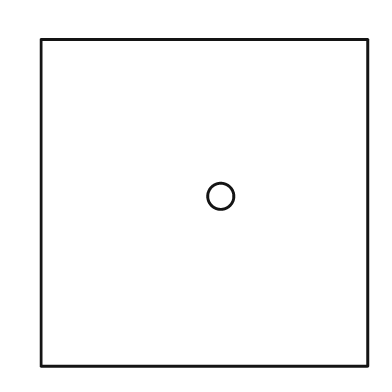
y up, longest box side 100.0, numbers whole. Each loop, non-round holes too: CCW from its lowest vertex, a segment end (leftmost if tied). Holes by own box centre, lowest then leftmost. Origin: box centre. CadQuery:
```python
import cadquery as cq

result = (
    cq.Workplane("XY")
    .moveTo(-50.0, -50.0)
    .lineTo(50.0, -50.0)
    .lineTo(50.0, 50.0)
    .lineTo(-50.0, 50.0)
    .close()
    .moveTo(5.0, 2.0)
    .circle(4.0)
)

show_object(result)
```